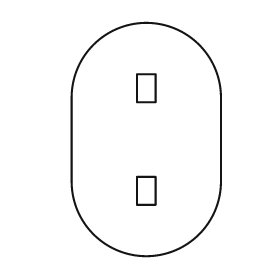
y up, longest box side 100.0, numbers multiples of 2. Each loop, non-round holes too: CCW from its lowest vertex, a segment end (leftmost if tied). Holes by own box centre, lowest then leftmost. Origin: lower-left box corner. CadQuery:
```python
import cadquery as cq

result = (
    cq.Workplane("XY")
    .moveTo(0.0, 32.0)
    .threePointArc((32.0, 0.0), (64.0, 32.0))
    .lineTo(64.0, 68.0)
    .threePointArc((32.0, 100.0), (0.0, 68.0))
    .close()
    .moveTo(28.0, 22.0)
    .lineTo(36.0, 22.0)
    .lineTo(36.0, 34.0)
    .lineTo(28.0, 34.0)
    .close()
    .moveTo(28.0, 66.0)
    .lineTo(36.0, 66.0)
    .lineTo(36.0, 78.0)
    .lineTo(28.0, 78.0)
    .close()
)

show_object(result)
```